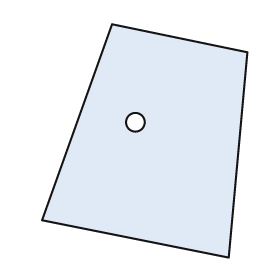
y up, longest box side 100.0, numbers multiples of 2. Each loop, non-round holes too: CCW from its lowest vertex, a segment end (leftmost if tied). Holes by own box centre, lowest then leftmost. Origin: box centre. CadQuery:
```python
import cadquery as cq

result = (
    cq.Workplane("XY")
    .moveTo(36.0, -50.0)
    .lineTo(44.0, 38.0)
    .lineTo(-14.0, 50.0)
    .lineTo(-44.0, -34.0)
    .close()
    .moveTo(-4.0, 8.0)
    .circle(4.0)
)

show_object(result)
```